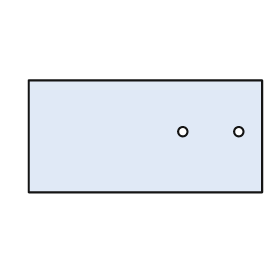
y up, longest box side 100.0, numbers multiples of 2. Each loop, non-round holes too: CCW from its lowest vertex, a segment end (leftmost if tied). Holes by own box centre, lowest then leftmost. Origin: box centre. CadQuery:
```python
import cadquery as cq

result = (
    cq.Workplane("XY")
    .moveTo(-50.0, -24.0)
    .lineTo(50.0, -24.0)
    .lineTo(50.0, 24.0)
    .lineTo(-50.0, 24.0)
    .close()
    .moveTo(16.0, 2.0)
    .circle(2.0)
    .moveTo(40.0, 2.0)
    .circle(2.0)
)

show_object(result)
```